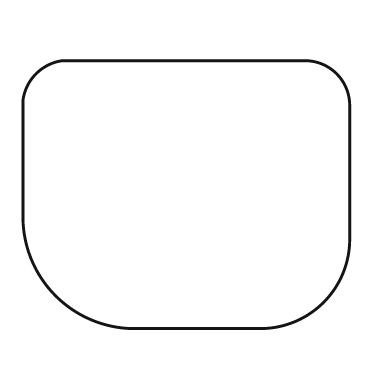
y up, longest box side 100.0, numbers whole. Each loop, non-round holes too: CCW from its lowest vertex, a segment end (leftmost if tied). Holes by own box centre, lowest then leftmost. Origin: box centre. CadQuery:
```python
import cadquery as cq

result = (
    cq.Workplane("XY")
    .moveTo(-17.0, -41.0)
    .lineTo(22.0, -41.0)
    .threePointArc((42.0, -33.0), (50.0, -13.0))
    .lineTo(50.0, 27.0)
    .threePointArc((46.0, 37.0), (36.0, 41.0))
    .lineTo(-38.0, 41.0)
    .threePointArc((-46.0, 37.0), (-50.0, 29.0))
    .lineTo(-50.0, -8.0)
    .threePointArc((-40.0, -31.0), (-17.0, -41.0))
    .close()
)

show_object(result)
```